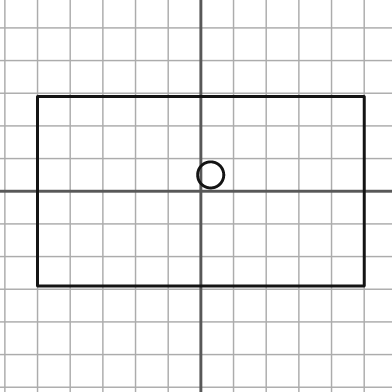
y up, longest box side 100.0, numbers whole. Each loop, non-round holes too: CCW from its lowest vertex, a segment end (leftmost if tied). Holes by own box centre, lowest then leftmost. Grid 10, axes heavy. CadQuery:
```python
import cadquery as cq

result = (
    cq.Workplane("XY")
    .moveTo(-50.0, -29.0)
    .lineTo(50.0, -29.0)
    .lineTo(50.0, 29.0)
    .lineTo(-50.0, 29.0)
    .close()
    .moveTo(3.0, 5.0)
    .circle(4.0)
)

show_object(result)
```